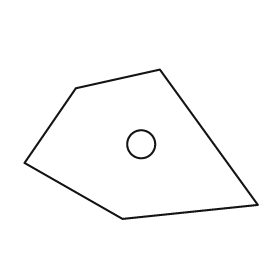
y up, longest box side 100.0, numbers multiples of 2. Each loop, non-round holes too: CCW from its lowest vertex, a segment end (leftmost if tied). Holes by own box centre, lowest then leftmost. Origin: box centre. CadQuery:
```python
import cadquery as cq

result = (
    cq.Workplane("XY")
    .moveTo(-8.0, -32.0)
    .lineTo(50.0, -26.0)
    .lineTo(8.0, 32.0)
    .lineTo(-28.0, 24.0)
    .lineTo(-50.0, -8.0)
    .close()
    .moveTo(0.0, 0.0)
    .circle(6.0)
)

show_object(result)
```